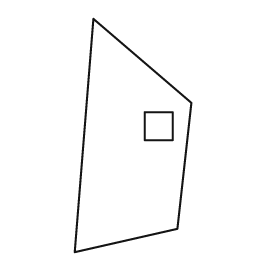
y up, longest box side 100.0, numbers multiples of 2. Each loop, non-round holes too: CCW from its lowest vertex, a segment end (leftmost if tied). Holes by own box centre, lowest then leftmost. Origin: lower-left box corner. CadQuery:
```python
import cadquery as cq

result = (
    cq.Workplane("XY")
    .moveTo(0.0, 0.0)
    .lineTo(44.0, 10.0)
    .lineTo(50.0, 64.0)
    .lineTo(8.0, 100.0)
    .close()
    .moveTo(30.0, 48.0)
    .lineTo(42.0, 48.0)
    .lineTo(42.0, 60.0)
    .lineTo(30.0, 60.0)
    .close()
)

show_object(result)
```